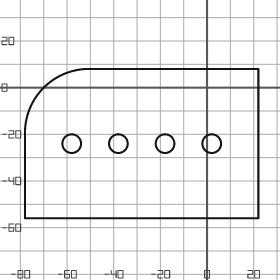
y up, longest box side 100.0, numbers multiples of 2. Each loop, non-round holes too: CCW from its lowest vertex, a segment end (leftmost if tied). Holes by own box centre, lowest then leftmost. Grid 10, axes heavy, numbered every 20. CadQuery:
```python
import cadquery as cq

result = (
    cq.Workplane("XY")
    .moveTo(-78.0, -56.0)
    .lineTo(22.0, -56.0)
    .lineTo(22.0, 8.0)
    .lineTo(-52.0, 8.0)
    .threePointArc((-70.0, 0.0), (-78.0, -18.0))
    .close()
    .moveTo(-58.0, -24.0)
    .circle(4.0)
    .moveTo(-38.0, -24.0)
    .circle(4.0)
    .moveTo(-18.0, -24.0)
    .circle(4.0)
    .moveTo(2.0, -24.0)
    .circle(4.0)
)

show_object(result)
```